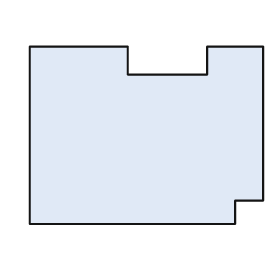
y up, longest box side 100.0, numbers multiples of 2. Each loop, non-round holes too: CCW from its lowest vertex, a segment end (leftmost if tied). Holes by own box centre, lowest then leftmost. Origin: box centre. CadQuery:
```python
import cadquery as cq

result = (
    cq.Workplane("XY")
    .moveTo(-50.0, -38.0)
    .lineTo(38.0, -38.0)
    .lineTo(38.0, -28.0)
    .lineTo(50.0, -28.0)
    .lineTo(50.0, 38.0)
    .lineTo(26.0, 38.0)
    .lineTo(26.0, 26.0)
    .lineTo(-8.0, 26.0)
    .lineTo(-8.0, 38.0)
    .lineTo(-50.0, 38.0)
    .close()
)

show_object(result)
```